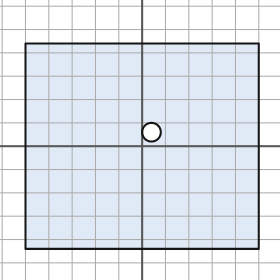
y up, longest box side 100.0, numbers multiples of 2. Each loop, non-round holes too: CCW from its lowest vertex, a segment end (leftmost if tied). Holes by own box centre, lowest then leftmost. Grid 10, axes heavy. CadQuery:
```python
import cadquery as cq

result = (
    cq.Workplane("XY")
    .moveTo(-50.0, -44.0)
    .lineTo(50.0, -44.0)
    .lineTo(50.0, 44.0)
    .lineTo(-50.0, 44.0)
    .close()
    .moveTo(4.0, 6.0)
    .circle(4.0)
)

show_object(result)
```